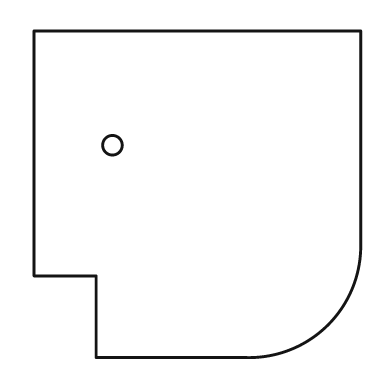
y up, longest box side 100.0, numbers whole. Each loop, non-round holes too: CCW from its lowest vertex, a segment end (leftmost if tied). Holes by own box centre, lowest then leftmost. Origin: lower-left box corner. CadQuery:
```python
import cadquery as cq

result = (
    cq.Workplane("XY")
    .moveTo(19.0, 0.0)
    .lineTo(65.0, 0.0)
    .threePointArc((90.0, 10.0), (100.0, 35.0))
    .lineTo(100.0, 100.0)
    .lineTo(0.0, 100.0)
    .lineTo(0.0, 25.0)
    .lineTo(19.0, 25.0)
    .close()
    .moveTo(24.0, 65.0)
    .circle(3.0)
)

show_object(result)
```